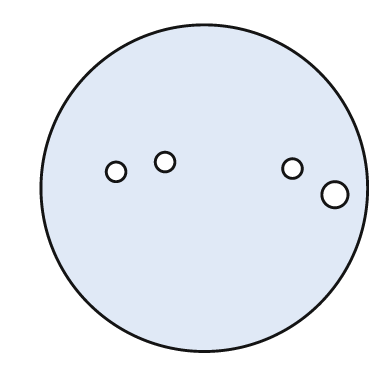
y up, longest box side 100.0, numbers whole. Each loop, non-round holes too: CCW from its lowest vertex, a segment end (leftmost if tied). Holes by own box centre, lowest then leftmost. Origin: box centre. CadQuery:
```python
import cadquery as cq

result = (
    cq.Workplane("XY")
    .moveTo(0.0, 0.0)
    .circle(50.0)
    .moveTo(40.0, -2.0)
    .circle(4.0)
    .moveTo(-27.0, 5.0)
    .circle(3.0)
    .moveTo(27.0, 6.0)
    .circle(3.0)
    .moveTo(-12.0, 8.0)
    .circle(3.0)
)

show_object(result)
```